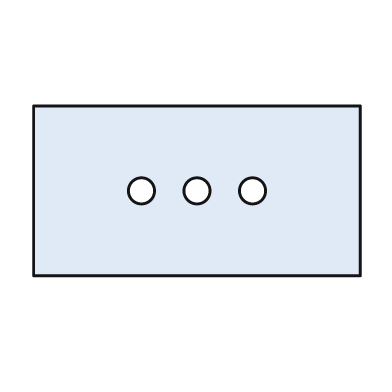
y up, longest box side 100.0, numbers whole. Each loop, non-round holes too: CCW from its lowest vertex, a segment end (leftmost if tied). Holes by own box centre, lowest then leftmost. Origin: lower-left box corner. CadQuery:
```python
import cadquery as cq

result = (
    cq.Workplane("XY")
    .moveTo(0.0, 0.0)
    .lineTo(100.0, 0.0)
    .lineTo(100.0, 52.0)
    .lineTo(0.0, 52.0)
    .close()
    .moveTo(33.0, 26.0)
    .circle(4.0)
    .moveTo(50.0, 26.0)
    .circle(4.0)
    .moveTo(67.0, 26.0)
    .circle(4.0)
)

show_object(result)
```